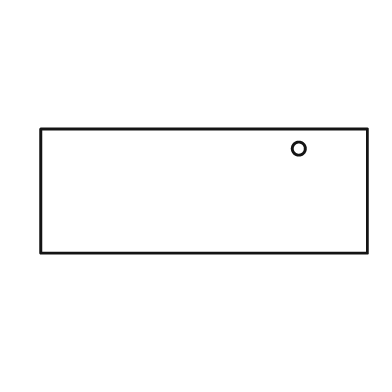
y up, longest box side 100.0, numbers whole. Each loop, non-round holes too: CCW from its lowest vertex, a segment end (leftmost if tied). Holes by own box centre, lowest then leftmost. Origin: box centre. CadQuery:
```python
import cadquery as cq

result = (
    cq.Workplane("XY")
    .moveTo(-50.0, -19.0)
    .lineTo(50.0, -19.0)
    .lineTo(50.0, 19.0)
    .lineTo(-50.0, 19.0)
    .close()
    .moveTo(29.0, 13.0)
    .circle(2.0)
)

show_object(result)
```